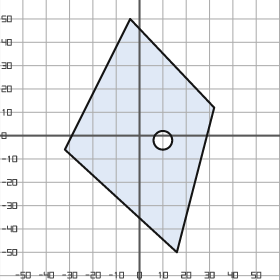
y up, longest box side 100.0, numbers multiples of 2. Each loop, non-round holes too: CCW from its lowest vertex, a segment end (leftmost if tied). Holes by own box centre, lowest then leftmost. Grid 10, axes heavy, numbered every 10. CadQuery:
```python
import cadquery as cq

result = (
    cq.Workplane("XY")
    .moveTo(16.0, -50.0)
    .lineTo(32.0, 12.0)
    .lineTo(-4.0, 50.0)
    .lineTo(-32.0, -6.0)
    .close()
    .moveTo(10.0, -2.0)
    .circle(4.0)
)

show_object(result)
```